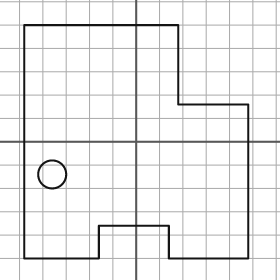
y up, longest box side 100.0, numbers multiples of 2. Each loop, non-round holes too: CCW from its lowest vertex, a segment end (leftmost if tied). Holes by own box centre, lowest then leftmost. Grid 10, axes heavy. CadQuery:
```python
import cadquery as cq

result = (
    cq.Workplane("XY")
    .moveTo(-48.0, -50.0)
    .lineTo(-16.0, -50.0)
    .lineTo(-16.0, -36.0)
    .lineTo(14.0, -36.0)
    .lineTo(14.0, -50.0)
    .lineTo(48.0, -50.0)
    .lineTo(48.0, 16.0)
    .lineTo(18.0, 16.0)
    .lineTo(18.0, 50.0)
    .lineTo(-48.0, 50.0)
    .close()
    .moveTo(-36.0, -14.0)
    .circle(6.0)
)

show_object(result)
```